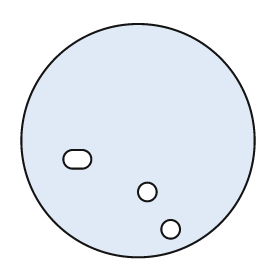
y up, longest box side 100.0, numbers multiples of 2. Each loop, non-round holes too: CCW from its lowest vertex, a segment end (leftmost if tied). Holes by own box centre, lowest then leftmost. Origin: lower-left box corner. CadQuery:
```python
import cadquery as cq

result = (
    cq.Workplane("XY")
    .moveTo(50.0, 50.0)
    .circle(50.0)
    .moveTo(64.0, 12.0)
    .circle(4.0)
    .moveTo(54.0, 28.0)
    .circle(4.0)
    .moveTo(22.0, 38.0)
    .lineTo(26.0, 38.0)
    .threePointArc((30.0, 42.0), (26.0, 46.0))
    .lineTo(22.0, 46.0)
    .threePointArc((18.0, 42.0), (22.0, 38.0))
    .close()
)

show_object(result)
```